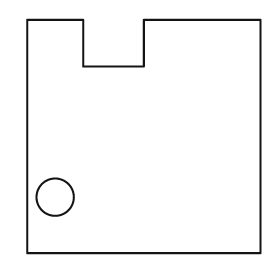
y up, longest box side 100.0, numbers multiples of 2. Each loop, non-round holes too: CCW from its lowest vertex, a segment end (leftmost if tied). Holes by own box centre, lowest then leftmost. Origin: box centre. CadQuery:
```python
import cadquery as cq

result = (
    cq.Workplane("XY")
    .moveTo(-50.0, -50.0)
    .lineTo(50.0, -50.0)
    .lineTo(50.0, 50.0)
    .lineTo(0.0, 50.0)
    .lineTo(0.0, 30.0)
    .lineTo(-26.0, 30.0)
    .lineTo(-26.0, 50.0)
    .lineTo(-50.0, 50.0)
    .close()
    .moveTo(-38.0, -26.0)
    .circle(8.0)
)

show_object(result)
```